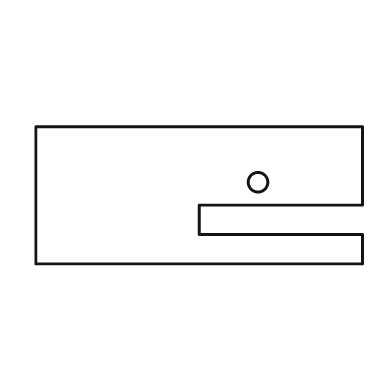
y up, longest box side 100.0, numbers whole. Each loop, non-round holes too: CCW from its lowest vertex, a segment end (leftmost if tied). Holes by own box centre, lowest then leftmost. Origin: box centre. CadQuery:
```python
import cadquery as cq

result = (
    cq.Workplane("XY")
    .moveTo(-50.0, -21.0)
    .lineTo(50.0, -21.0)
    .lineTo(50.0, -12.0)
    .lineTo(0.0, -12.0)
    .lineTo(0.0, -3.0)
    .lineTo(50.0, -3.0)
    .lineTo(50.0, 21.0)
    .lineTo(-50.0, 21.0)
    .close()
    .moveTo(18.0, 4.0)
    .circle(3.0)
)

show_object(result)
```